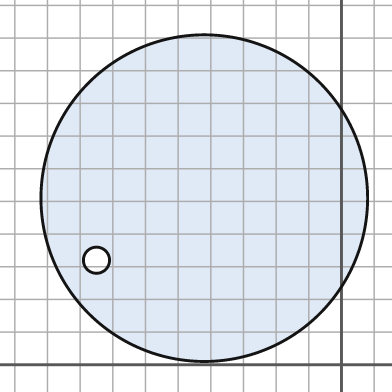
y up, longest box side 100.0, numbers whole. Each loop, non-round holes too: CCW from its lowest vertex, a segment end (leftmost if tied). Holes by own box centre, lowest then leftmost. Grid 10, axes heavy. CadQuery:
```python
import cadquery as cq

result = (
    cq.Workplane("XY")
    .moveTo(-42.0, 51.0)
    .circle(50.0)
    .moveTo(-75.0, 32.0)
    .circle(4.0)
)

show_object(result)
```